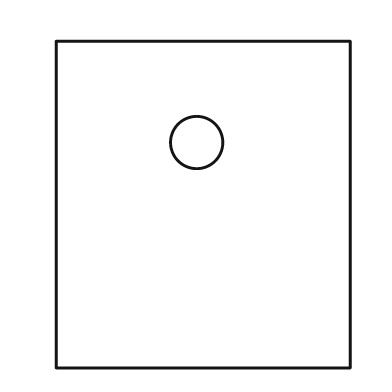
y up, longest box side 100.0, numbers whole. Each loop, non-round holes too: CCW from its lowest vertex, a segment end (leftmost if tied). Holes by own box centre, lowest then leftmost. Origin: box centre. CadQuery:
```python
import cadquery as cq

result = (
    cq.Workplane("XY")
    .moveTo(-45.0, -50.0)
    .lineTo(45.0, -50.0)
    .lineTo(45.0, 50.0)
    .lineTo(-45.0, 50.0)
    .close()
    .moveTo(-2.0, 19.0)
    .circle(8.0)
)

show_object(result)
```